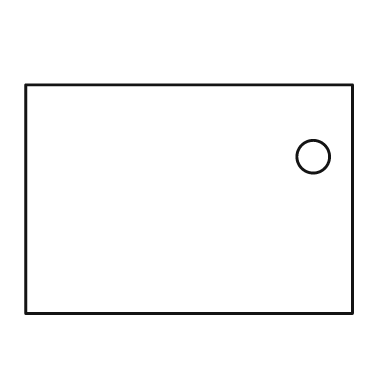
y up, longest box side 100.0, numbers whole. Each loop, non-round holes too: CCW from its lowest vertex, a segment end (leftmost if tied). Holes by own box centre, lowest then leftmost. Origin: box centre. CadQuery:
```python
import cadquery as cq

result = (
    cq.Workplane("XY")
    .moveTo(-50.0, -35.0)
    .lineTo(50.0, -35.0)
    .lineTo(50.0, 35.0)
    .lineTo(-50.0, 35.0)
    .close()
    .moveTo(38.0, 13.0)
    .circle(5.0)
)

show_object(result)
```